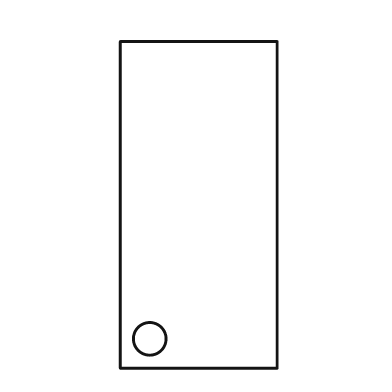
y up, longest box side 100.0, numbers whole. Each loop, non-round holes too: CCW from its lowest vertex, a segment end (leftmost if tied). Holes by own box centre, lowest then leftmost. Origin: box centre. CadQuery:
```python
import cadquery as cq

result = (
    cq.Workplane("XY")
    .moveTo(-24.0, -50.0)
    .lineTo(24.0, -50.0)
    .lineTo(24.0, 50.0)
    .lineTo(-24.0, 50.0)
    .close()
    .moveTo(-15.0, -41.0)
    .circle(5.0)
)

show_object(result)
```